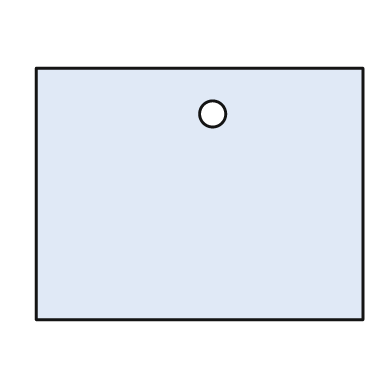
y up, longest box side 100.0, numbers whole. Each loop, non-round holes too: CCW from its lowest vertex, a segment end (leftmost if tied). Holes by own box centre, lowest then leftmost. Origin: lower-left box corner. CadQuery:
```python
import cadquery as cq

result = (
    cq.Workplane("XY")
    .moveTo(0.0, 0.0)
    .lineTo(100.0, 0.0)
    .lineTo(100.0, 77.0)
    .lineTo(0.0, 77.0)
    .close()
    .moveTo(54.0, 63.0)
    .circle(4.0)
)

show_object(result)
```